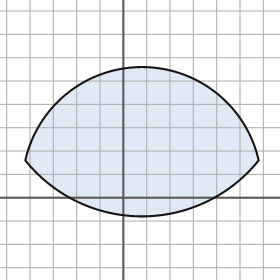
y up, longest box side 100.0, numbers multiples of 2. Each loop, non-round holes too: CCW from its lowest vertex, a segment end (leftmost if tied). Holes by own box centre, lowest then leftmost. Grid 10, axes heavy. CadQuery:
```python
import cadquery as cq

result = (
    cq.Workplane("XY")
    .moveTo(-42.0, 16.0)
    .threePointArc((8.0, -8.0), (58.0, 16.0))
    .threePointArc((8.0, 56.0), (-42.0, 16.0))
    .close()
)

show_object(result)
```